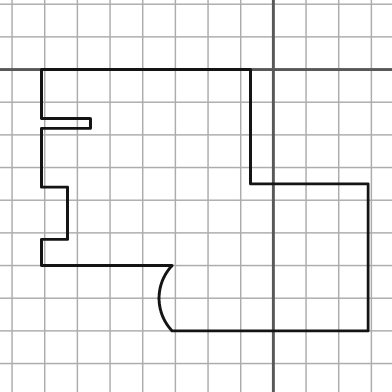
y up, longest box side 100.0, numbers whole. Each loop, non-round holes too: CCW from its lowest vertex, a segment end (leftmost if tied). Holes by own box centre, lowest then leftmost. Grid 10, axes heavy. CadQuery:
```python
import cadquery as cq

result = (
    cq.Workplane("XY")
    .moveTo(-31.0, -80.0)
    .lineTo(29.0, -80.0)
    .lineTo(29.0, -35.0)
    .lineTo(-7.0, -35.0)
    .lineTo(-7.0, 0.0)
    .lineTo(-71.0, 0.0)
    .lineTo(-71.0, -15.0)
    .lineTo(-56.0, -15.0)
    .lineTo(-56.0, -18.0)
    .lineTo(-71.0, -18.0)
    .lineTo(-71.0, -36.0)
    .lineTo(-63.0, -36.0)
    .lineTo(-63.0, -52.0)
    .lineTo(-71.0, -52.0)
    .lineTo(-71.0, -60.0)
    .lineTo(-31.0, -60.0)
    .threePointArc((-35.0, -70.0), (-31.0, -80.0))
    .close()
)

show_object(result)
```